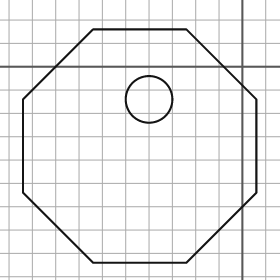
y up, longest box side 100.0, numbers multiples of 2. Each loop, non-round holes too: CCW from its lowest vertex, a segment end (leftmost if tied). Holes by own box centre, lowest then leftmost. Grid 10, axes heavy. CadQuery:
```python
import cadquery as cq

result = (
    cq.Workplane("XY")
    .moveTo(-64.0, -84.0)
    .lineTo(-24.0, -84.0)
    .lineTo(6.0, -54.0)
    .lineTo(6.0, -14.0)
    .lineTo(-24.0, 16.0)
    .lineTo(-64.0, 16.0)
    .lineTo(-94.0, -14.0)
    .lineTo(-94.0, -54.0)
    .close()
    .moveTo(-40.0, -14.0)
    .circle(10.0)
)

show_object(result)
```